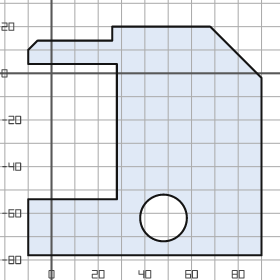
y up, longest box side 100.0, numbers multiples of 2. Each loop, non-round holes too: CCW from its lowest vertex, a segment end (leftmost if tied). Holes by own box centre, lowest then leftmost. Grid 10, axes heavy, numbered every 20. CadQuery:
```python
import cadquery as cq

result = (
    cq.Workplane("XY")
    .moveTo(-10.0, -78.0)
    .lineTo(90.0, -78.0)
    .lineTo(90.0, -2.0)
    .lineTo(68.0, 20.0)
    .lineTo(26.0, 20.0)
    .lineTo(26.0, 14.0)
    .lineTo(-6.0, 14.0)
    .lineTo(-10.0, 10.0)
    .lineTo(-10.0, 4.0)
    .lineTo(28.0, 4.0)
    .lineTo(28.0, -54.0)
    .lineTo(-10.0, -54.0)
    .close()
    .moveTo(48.0, -62.0)
    .circle(10.0)
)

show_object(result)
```